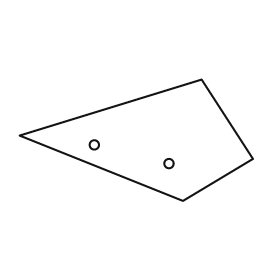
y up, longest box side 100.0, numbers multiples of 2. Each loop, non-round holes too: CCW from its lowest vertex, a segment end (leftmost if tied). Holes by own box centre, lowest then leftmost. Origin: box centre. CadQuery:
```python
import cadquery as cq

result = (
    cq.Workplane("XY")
    .moveTo(20.0, -26.0)
    .lineTo(50.0, -8.0)
    .lineTo(28.0, 26.0)
    .lineTo(-50.0, 2.0)
    .close()
    .moveTo(14.0, -10.0)
    .circle(2.0)
    .moveTo(-18.0, -2.0)
    .circle(2.0)
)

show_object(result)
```